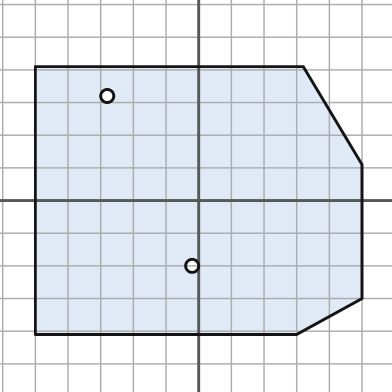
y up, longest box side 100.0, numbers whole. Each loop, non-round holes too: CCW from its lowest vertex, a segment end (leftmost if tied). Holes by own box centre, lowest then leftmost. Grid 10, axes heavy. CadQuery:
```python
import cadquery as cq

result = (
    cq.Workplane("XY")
    .moveTo(-50.0, -41.0)
    .lineTo(30.0, -41.0)
    .lineTo(50.0, -30.0)
    .lineTo(50.0, 11.0)
    .lineTo(32.0, 41.0)
    .lineTo(-50.0, 41.0)
    .close()
    .moveTo(-2.0, -20.0)
    .circle(2.0)
    .moveTo(-28.0, 32.0)
    .circle(2.0)
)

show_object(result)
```